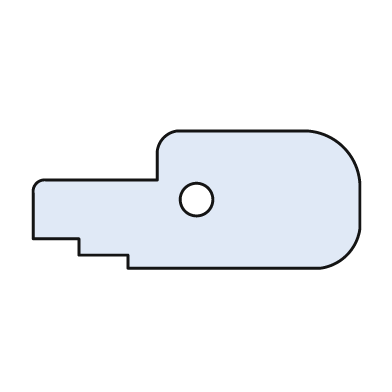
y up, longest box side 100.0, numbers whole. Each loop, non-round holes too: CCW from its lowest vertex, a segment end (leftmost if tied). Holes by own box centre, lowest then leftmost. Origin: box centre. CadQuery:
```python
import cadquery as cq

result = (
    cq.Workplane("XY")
    .moveTo(-21.0, -21.0)
    .lineTo(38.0, -21.0)
    .threePointArc((46.0, -17.0), (50.0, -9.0))
    .lineTo(50.0, 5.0)
    .threePointArc((45.0, 16.0), (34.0, 21.0))
    .lineTo(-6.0, 21.0)
    .threePointArc((-10.0, 19.0), (-12.0, 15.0))
    .lineTo(-12.0, 6.0)
    .lineTo(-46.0, 6.0)
    .threePointArc((-49.0, 5.0), (-50.0, 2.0))
    .lineTo(-50.0, -12.0)
    .lineTo(-36.0, -12.0)
    .lineTo(-36.0, -17.0)
    .lineTo(-21.0, -17.0)
    .close()
    .moveTo(0.0, 0.0)
    .circle(5.0)
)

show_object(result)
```